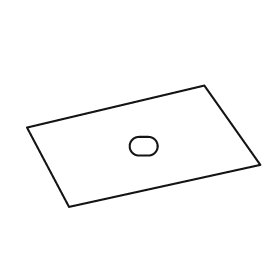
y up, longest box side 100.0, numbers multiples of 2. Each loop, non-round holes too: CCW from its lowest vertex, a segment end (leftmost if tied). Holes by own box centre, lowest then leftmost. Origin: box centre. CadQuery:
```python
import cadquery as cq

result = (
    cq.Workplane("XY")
    .moveTo(-32.0, -26.0)
    .lineTo(50.0, -8.0)
    .lineTo(26.0, 26.0)
    .lineTo(-50.0, 8.0)
    .close()
    .moveTo(-2.0, -4.0)
    .lineTo(2.0, -4.0)
    .threePointArc((6.0, 0.0), (2.0, 4.0))
    .lineTo(-2.0, 4.0)
    .threePointArc((-6.0, 0.0), (-2.0, -4.0))
    .close()
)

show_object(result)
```